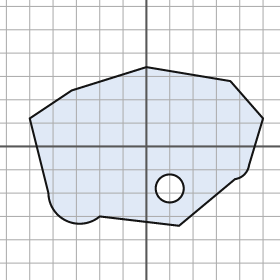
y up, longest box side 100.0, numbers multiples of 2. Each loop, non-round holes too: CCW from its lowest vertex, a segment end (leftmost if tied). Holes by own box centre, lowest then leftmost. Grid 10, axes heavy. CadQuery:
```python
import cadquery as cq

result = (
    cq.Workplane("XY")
    .moveTo(14.0, -34.0)
    .lineTo(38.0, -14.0)
    .threePointArc((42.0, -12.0), (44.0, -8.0))
    .lineTo(50.0, 12.0)
    .lineTo(36.0, 28.0)
    .lineTo(0.0, 34.0)
    .lineTo(-32.0, 24.0)
    .lineTo(-50.0, 12.0)
    .lineTo(-42.0, -20.0)
    .threePointArc((-34.0, -32.0), (-20.0, -30.0))
    .close()
    .moveTo(10.0, -18.0)
    .circle(6.0)
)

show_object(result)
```